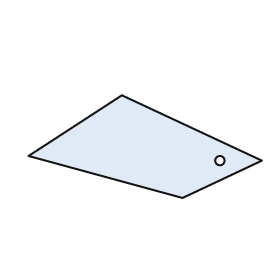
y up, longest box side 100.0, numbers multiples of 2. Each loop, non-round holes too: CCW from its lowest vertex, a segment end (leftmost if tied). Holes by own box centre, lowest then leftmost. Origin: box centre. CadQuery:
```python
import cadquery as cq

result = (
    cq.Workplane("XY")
    .moveTo(16.0, -22.0)
    .lineTo(50.0, -6.0)
    .lineTo(-10.0, 22.0)
    .lineTo(-50.0, -4.0)
    .close()
    .moveTo(32.0, -6.0)
    .circle(2.0)
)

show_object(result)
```